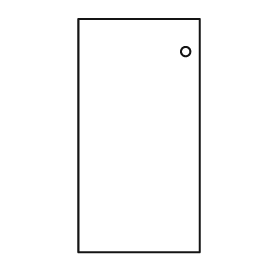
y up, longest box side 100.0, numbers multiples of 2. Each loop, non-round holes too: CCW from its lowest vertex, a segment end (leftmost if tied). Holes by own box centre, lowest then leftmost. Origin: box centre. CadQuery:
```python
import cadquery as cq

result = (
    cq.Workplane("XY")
    .moveTo(-26.0, -50.0)
    .lineTo(26.0, -50.0)
    .lineTo(26.0, 50.0)
    .lineTo(-26.0, 50.0)
    .close()
    .moveTo(20.0, 36.0)
    .circle(2.0)
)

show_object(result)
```